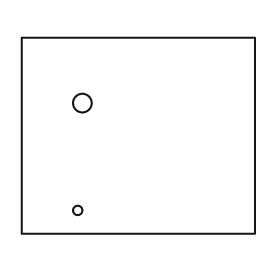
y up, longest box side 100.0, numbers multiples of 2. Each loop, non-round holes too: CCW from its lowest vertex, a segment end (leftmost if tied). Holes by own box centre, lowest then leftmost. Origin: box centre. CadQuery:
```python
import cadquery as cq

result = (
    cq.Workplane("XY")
    .moveTo(-50.0, -42.0)
    .lineTo(50.0, -42.0)
    .lineTo(50.0, 42.0)
    .lineTo(-50.0, 42.0)
    .close()
    .moveTo(-26.0, -32.0)
    .circle(2.0)
    .moveTo(-24.0, 14.0)
    .circle(4.0)
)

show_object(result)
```